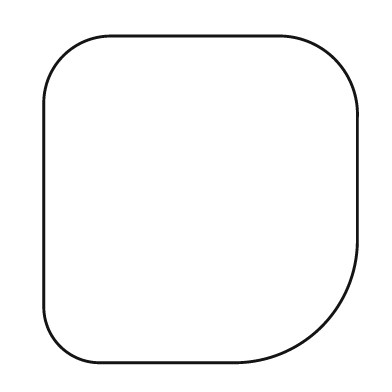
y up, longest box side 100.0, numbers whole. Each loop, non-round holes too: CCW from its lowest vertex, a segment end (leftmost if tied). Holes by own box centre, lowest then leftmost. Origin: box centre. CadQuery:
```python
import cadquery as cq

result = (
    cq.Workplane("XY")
    .moveTo(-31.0, -50.0)
    .lineTo(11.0, -50.0)
    .threePointArc((37.0, -39.0), (48.0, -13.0))
    .lineTo(48.0, 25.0)
    .threePointArc((41.0, 43.0), (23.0, 50.0))
    .lineTo(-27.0, 50.0)
    .threePointArc((-42.0, 44.0), (-48.0, 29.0))
    .lineTo(-48.0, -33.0)
    .threePointArc((-43.0, -45.0), (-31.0, -50.0))
    .close()
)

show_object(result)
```